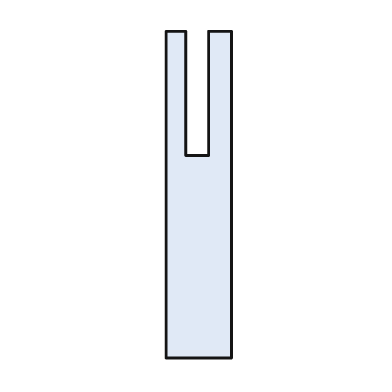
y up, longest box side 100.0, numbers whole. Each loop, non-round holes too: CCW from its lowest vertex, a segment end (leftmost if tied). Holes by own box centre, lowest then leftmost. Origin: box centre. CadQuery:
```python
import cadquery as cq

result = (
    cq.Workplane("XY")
    .moveTo(-10.0, -50.0)
    .lineTo(10.0, -50.0)
    .lineTo(10.0, 50.0)
    .lineTo(3.0, 50.0)
    .lineTo(3.0, 12.0)
    .lineTo(-4.0, 12.0)
    .lineTo(-4.0, 50.0)
    .lineTo(-10.0, 50.0)
    .close()
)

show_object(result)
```